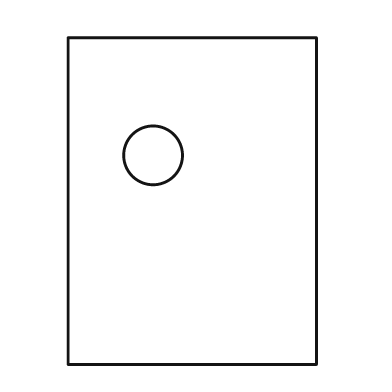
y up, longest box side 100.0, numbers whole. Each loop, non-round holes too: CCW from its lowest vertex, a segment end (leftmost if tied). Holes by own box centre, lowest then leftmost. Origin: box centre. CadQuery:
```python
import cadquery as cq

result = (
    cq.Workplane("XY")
    .moveTo(-38.0, -50.0)
    .lineTo(38.0, -50.0)
    .lineTo(38.0, 50.0)
    .lineTo(-38.0, 50.0)
    .close()
    .moveTo(-12.0, 14.0)
    .circle(9.0)
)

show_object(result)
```